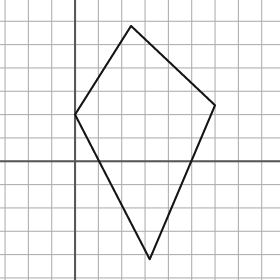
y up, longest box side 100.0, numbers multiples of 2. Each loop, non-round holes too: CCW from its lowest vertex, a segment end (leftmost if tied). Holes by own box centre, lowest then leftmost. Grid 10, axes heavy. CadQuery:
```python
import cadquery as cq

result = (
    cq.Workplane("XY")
    .moveTo(32.0, -42.0)
    .lineTo(60.0, 24.0)
    .lineTo(24.0, 58.0)
    .lineTo(0.0, 20.0)
    .close()
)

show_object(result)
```